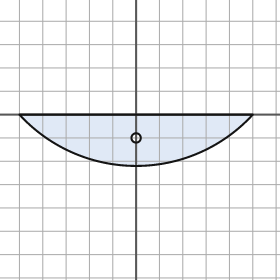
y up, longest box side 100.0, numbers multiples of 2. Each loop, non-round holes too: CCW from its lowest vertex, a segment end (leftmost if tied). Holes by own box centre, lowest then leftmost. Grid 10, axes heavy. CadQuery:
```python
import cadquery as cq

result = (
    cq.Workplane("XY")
    .moveTo(-50.0, 0.0)
    .threePointArc((0.0, -22.0), (50.0, 0.0))
    .close()
    .moveTo(0.0, -10.0)
    .circle(2.0)
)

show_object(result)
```